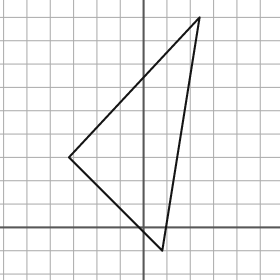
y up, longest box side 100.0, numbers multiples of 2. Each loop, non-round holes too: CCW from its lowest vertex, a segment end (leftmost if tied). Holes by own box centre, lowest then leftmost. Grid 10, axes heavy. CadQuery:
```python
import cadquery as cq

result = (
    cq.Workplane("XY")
    .moveTo(8.0, -10.0)
    .lineTo(24.0, 90.0)
    .lineTo(-32.0, 30.0)
    .close()
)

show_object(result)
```